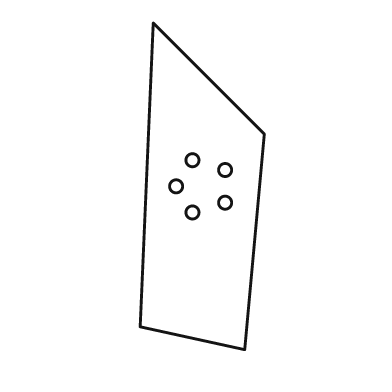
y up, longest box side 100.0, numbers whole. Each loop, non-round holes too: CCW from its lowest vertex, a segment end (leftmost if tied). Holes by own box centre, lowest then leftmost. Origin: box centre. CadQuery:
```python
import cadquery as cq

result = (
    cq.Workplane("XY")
    .moveTo(13.0, -50.0)
    .lineTo(19.0, 16.0)
    .lineTo(-15.0, 50.0)
    .lineTo(-19.0, -43.0)
    .close()
    .moveTo(-3.0, -8.0)
    .circle(2.0)
    .moveTo(7.0, -5.0)
    .circle(2.0)
    .moveTo(-8.0, 0.0)
    .circle(2.0)
    .moveTo(7.0, 5.0)
    .circle(2.0)
    .moveTo(-3.0, 8.0)
    .circle(2.0)
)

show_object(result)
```